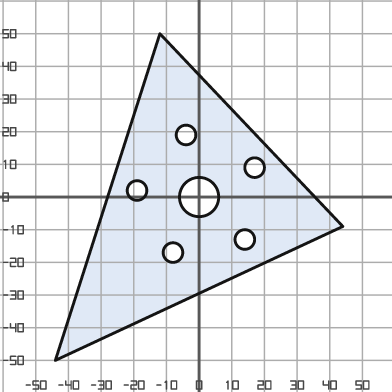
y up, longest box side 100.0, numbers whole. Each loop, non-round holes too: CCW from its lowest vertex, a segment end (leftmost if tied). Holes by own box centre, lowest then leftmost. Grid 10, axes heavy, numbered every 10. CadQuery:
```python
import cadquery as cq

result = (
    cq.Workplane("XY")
    .moveTo(-44.0, -50.0)
    .lineTo(44.0, -9.0)
    .lineTo(-12.0, 50.0)
    .close()
    .moveTo(-8.0, -17.0)
    .circle(3.0)
    .moveTo(14.0, -13.0)
    .circle(3.0)
    .moveTo(0.0, 0.0)
    .circle(6.0)
    .moveTo(-19.0, 2.0)
    .circle(3.0)
    .moveTo(17.0, 9.0)
    .circle(3.0)
    .moveTo(-4.0, 19.0)
    .circle(3.0)
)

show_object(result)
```